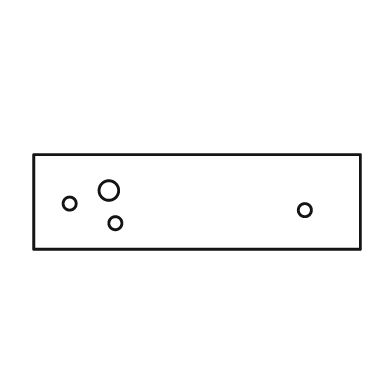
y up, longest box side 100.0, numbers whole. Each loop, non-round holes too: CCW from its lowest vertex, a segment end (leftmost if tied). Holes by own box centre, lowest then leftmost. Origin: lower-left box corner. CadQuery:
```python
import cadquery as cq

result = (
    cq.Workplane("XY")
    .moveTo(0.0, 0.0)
    .lineTo(100.0, 0.0)
    .lineTo(100.0, 29.0)
    .lineTo(0.0, 29.0)
    .close()
    .moveTo(25.0, 8.0)
    .circle(2.0)
    .moveTo(83.0, 12.0)
    .circle(2.0)
    .moveTo(11.0, 14.0)
    .circle(2.0)
    .moveTo(23.0, 18.0)
    .circle(3.0)
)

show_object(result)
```